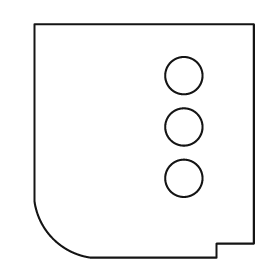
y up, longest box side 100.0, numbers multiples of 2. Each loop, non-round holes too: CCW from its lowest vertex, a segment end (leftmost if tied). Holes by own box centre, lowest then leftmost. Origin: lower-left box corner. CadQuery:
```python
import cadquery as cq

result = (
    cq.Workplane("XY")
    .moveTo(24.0, 0.0)
    .lineTo(78.0, 0.0)
    .lineTo(78.0, 6.0)
    .lineTo(94.0, 6.0)
    .lineTo(94.0, 100.0)
    .lineTo(0.0, 100.0)
    .lineTo(0.0, 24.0)
    .threePointArc((8.0, 8.0), (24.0, 0.0))
    .close()
    .moveTo(64.0, 34.0)
    .circle(8.0)
    .moveTo(64.0, 56.0)
    .circle(8.0)
    .moveTo(64.0, 78.0)
    .circle(8.0)
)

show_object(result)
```